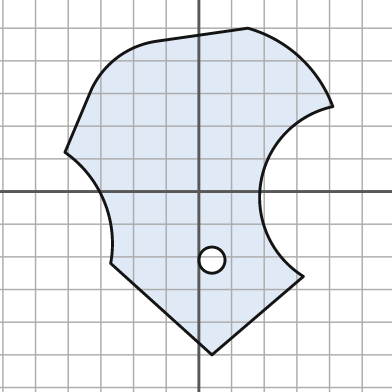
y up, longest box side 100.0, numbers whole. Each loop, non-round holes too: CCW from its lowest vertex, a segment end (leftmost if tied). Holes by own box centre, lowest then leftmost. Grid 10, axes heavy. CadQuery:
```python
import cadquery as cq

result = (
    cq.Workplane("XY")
    .moveTo(4.0, -50.0)
    .lineTo(32.0, -26.0)
    .threePointArc((19.0, 3.0), (41.0, 26.0))
    .threePointArc((31.0, 41.0), (15.0, 50.0))
    .lineTo(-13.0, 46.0)
    .threePointArc((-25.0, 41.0), (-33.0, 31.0))
    .lineTo(-41.0, 12.0)
    .threePointArc((-29.0, -3.0), (-27.0, -22.0))
    .close()
    .moveTo(4.0, -21.0)
    .circle(4.0)
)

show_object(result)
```